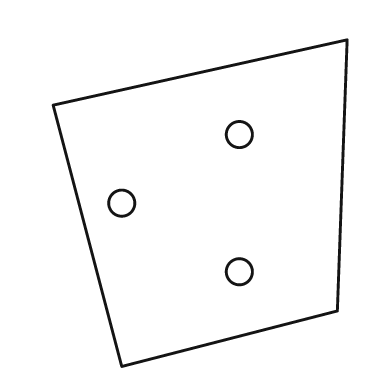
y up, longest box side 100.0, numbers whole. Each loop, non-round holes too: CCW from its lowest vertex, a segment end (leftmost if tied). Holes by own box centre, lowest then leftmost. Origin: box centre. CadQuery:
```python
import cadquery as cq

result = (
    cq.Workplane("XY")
    .moveTo(-24.0, -50.0)
    .lineTo(42.0, -33.0)
    .lineTo(45.0, 50.0)
    .lineTo(-45.0, 30.0)
    .close()
    .moveTo(12.0, -21.0)
    .circle(4.0)
    .moveTo(-24.0, 0.0)
    .circle(4.0)
    .moveTo(12.0, 21.0)
    .circle(4.0)
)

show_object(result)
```